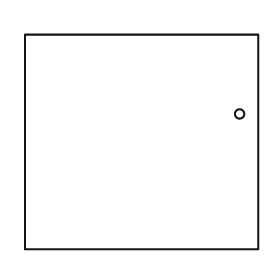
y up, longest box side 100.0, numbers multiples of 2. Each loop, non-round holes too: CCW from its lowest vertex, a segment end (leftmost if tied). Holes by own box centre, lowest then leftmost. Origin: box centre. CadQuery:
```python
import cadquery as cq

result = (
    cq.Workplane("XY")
    .moveTo(-50.0, -46.0)
    .lineTo(50.0, -46.0)
    .lineTo(50.0, 46.0)
    .lineTo(-50.0, 46.0)
    .close()
    .moveTo(42.0, 12.0)
    .circle(2.0)
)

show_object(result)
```